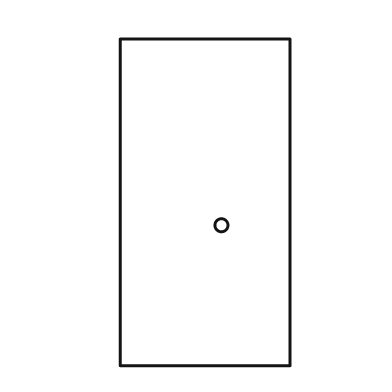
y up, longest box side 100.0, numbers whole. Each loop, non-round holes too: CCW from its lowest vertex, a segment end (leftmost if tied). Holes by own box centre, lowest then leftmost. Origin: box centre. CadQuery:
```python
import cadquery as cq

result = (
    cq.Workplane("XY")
    .moveTo(-26.0, -50.0)
    .lineTo(26.0, -50.0)
    .lineTo(26.0, 50.0)
    .lineTo(-26.0, 50.0)
    .close()
    .moveTo(5.0, -7.0)
    .circle(2.0)
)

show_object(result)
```